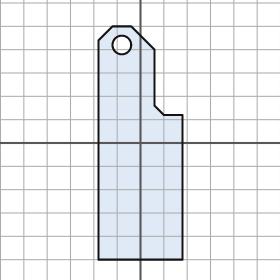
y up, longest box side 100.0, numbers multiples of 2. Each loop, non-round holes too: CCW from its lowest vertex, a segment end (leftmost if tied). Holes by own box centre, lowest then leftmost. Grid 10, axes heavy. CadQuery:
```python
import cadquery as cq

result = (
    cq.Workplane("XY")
    .moveTo(-18.0, -50.0)
    .lineTo(18.0, -50.0)
    .lineTo(18.0, 12.0)
    .lineTo(10.0, 12.0)
    .lineTo(6.0, 16.0)
    .lineTo(6.0, 40.0)
    .lineTo(-4.0, 50.0)
    .lineTo(-12.0, 50.0)
    .lineTo(-18.0, 44.0)
    .close()
    .moveTo(-8.0, 42.0)
    .circle(4.0)
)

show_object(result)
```